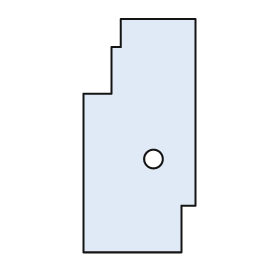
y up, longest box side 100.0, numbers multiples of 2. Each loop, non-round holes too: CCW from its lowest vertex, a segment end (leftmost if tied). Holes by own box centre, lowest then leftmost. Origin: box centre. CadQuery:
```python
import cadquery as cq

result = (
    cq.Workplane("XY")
    .moveTo(-24.0, -50.0)
    .lineTo(18.0, -50.0)
    .lineTo(18.0, -30.0)
    .lineTo(24.0, -30.0)
    .lineTo(24.0, 50.0)
    .lineTo(-8.0, 50.0)
    .lineTo(-8.0, 38.0)
    .lineTo(-12.0, 38.0)
    .lineTo(-12.0, 18.0)
    .lineTo(-24.0, 18.0)
    .close()
    .moveTo(6.0, -10.0)
    .circle(4.0)
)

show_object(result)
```